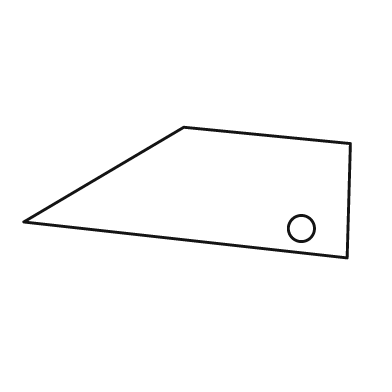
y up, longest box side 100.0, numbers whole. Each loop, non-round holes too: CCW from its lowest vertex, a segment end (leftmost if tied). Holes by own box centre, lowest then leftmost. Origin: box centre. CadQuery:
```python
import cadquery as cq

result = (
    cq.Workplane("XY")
    .moveTo(49.0, -20.0)
    .lineTo(50.0, 15.0)
    .lineTo(-1.0, 20.0)
    .lineTo(-50.0, -9.0)
    .close()
    .moveTo(35.0, -11.0)
    .circle(4.0)
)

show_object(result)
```